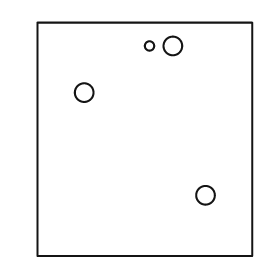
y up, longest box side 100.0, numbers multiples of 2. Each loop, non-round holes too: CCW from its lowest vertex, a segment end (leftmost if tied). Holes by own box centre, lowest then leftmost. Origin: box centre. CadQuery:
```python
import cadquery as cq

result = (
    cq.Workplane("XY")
    .moveTo(-46.0, -50.0)
    .lineTo(46.0, -50.0)
    .lineTo(46.0, 50.0)
    .lineTo(-46.0, 50.0)
    .close()
    .moveTo(26.0, -24.0)
    .circle(4.0)
    .moveTo(-26.0, 20.0)
    .circle(4.0)
    .moveTo(2.0, 40.0)
    .circle(2.0)
    .moveTo(12.0, 40.0)
    .circle(4.0)
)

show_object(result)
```